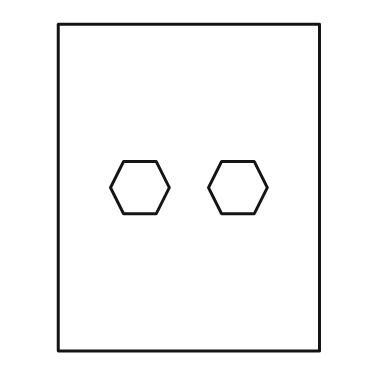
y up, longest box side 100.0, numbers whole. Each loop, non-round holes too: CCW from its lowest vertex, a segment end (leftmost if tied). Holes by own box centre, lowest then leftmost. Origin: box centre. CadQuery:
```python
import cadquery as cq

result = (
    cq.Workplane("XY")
    .moveTo(-40.0, -50.0)
    .lineTo(40.0, -50.0)
    .lineTo(40.0, 50.0)
    .lineTo(-40.0, 50.0)
    .close()
    .moveTo(-20.0, -8.0)
    .lineTo(-10.0, -8.0)
    .lineTo(-6.0, 0.0)
    .lineTo(-10.0, 8.0)
    .lineTo(-20.0, 8.0)
    .lineTo(-24.0, 0.0)
    .close()
    .moveTo(10.0, -8.0)
    .lineTo(20.0, -8.0)
    .lineTo(24.0, 0.0)
    .lineTo(20.0, 8.0)
    .lineTo(10.0, 8.0)
    .lineTo(6.0, 0.0)
    .close()
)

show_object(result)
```